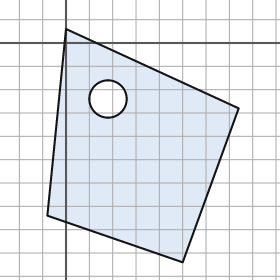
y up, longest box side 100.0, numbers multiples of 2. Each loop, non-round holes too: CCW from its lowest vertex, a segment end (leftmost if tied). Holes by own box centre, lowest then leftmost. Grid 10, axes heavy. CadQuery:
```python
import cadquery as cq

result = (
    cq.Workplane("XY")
    .moveTo(50.0, -94.0)
    .lineTo(74.0, -28.0)
    .lineTo(0.0, 6.0)
    .lineTo(-8.0, -74.0)
    .close()
    .moveTo(18.0, -24.0)
    .circle(8.0)
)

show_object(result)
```